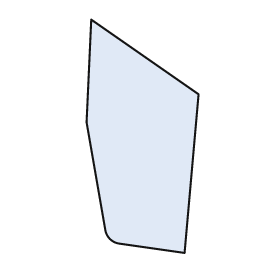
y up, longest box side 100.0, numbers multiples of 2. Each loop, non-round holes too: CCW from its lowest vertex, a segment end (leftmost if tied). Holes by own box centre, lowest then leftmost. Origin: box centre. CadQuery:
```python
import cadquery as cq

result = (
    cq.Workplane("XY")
    .moveTo(18.0, -50.0)
    .lineTo(24.0, 18.0)
    .lineTo(-22.0, 50.0)
    .lineTo(-24.0, 6.0)
    .lineTo(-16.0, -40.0)
    .threePointArc((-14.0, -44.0), (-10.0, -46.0))
    .close()
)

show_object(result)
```